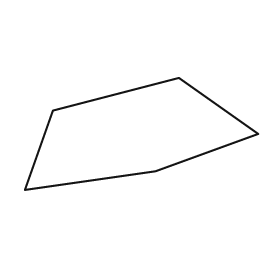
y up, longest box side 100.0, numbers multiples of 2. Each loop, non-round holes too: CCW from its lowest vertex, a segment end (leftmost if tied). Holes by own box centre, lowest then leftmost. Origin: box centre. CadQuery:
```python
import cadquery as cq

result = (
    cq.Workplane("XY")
    .moveTo(-50.0, -24.0)
    .lineTo(6.0, -16.0)
    .lineTo(50.0, 0.0)
    .lineTo(16.0, 24.0)
    .lineTo(-38.0, 10.0)
    .close()
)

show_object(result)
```